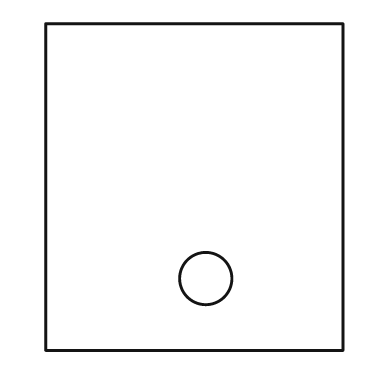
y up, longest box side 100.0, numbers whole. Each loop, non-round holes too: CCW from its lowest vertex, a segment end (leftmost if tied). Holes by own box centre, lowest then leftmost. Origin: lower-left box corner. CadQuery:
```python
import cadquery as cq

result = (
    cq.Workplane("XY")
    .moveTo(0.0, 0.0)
    .lineTo(91.0, 0.0)
    .lineTo(91.0, 100.0)
    .lineTo(0.0, 100.0)
    .close()
    .moveTo(49.0, 22.0)
    .circle(8.0)
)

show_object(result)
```